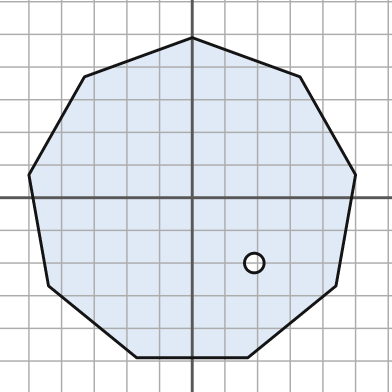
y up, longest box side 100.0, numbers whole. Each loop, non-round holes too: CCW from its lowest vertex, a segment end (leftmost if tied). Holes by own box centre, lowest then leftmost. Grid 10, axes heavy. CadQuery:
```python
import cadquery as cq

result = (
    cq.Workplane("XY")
    .moveTo(-17.0, -49.0)
    .lineTo(17.0, -49.0)
    .lineTo(44.0, -27.0)
    .lineTo(50.0, 7.0)
    .lineTo(33.0, 37.0)
    .lineTo(0.0, 49.0)
    .lineTo(-33.0, 37.0)
    .lineTo(-50.0, 7.0)
    .lineTo(-44.0, -27.0)
    .close()
    .moveTo(19.0, -20.0)
    .circle(3.0)
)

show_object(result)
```